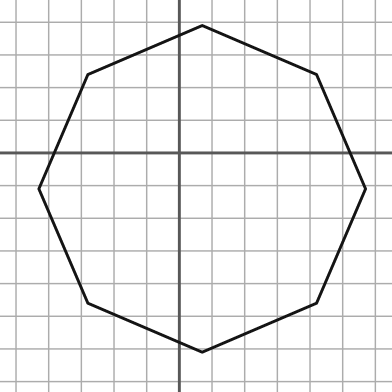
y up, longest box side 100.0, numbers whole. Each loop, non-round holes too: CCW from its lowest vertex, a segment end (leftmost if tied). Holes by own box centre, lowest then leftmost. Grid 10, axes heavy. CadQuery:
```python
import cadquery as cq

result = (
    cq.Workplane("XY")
    .moveTo(7.0, -61.0)
    .lineTo(42.0, -46.0)
    .lineTo(57.0, -11.0)
    .lineTo(42.0, 24.0)
    .lineTo(7.0, 39.0)
    .lineTo(-28.0, 24.0)
    .lineTo(-43.0, -11.0)
    .lineTo(-28.0, -46.0)
    .close()
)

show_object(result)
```